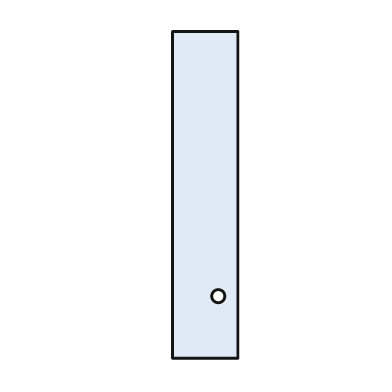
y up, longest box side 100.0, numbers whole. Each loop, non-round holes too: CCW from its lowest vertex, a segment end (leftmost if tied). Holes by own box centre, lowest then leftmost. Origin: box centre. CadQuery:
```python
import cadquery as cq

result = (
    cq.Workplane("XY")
    .moveTo(-10.0, -50.0)
    .lineTo(10.0, -50.0)
    .lineTo(10.0, 50.0)
    .lineTo(-10.0, 50.0)
    .close()
    .moveTo(4.0, -31.0)
    .circle(2.0)
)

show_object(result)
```